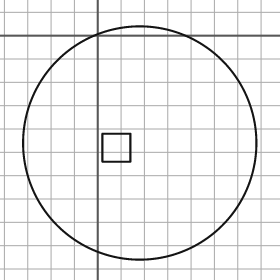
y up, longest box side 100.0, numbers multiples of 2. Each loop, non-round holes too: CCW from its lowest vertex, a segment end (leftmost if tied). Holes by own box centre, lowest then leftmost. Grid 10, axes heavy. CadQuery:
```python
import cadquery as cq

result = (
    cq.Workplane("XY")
    .moveTo(18.0, -46.0)
    .circle(50.0)
    .moveTo(2.0, -54.0)
    .lineTo(14.0, -54.0)
    .lineTo(14.0, -42.0)
    .lineTo(2.0, -42.0)
    .close()
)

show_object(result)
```